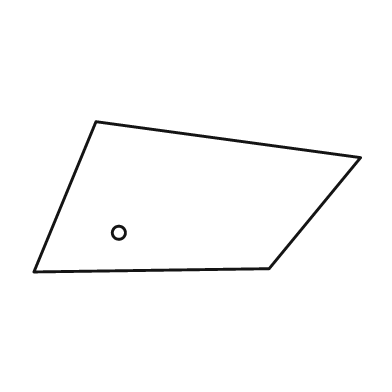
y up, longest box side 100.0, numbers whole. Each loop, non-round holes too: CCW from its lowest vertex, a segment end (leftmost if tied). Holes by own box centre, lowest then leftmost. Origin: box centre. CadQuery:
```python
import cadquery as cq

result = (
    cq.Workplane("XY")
    .moveTo(-50.0, -23.0)
    .lineTo(22.0, -22.0)
    .lineTo(50.0, 12.0)
    .lineTo(-31.0, 23.0)
    .close()
    .moveTo(-24.0, -11.0)
    .circle(2.0)
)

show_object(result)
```